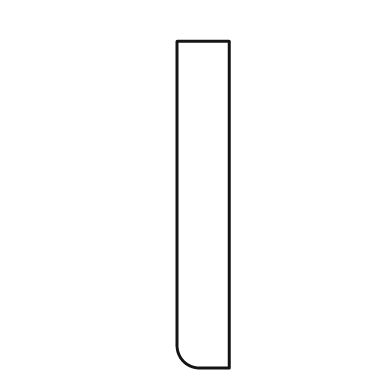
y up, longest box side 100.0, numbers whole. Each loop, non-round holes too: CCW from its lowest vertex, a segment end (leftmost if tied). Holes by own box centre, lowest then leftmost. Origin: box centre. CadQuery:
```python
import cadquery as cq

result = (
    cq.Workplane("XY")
    .moveTo(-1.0, -50.0)
    .lineTo(8.0, -50.0)
    .lineTo(8.0, 50.0)
    .lineTo(-8.0, 50.0)
    .lineTo(-8.0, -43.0)
    .threePointArc((-6.0, -48.0), (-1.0, -50.0))
    .close()
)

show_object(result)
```